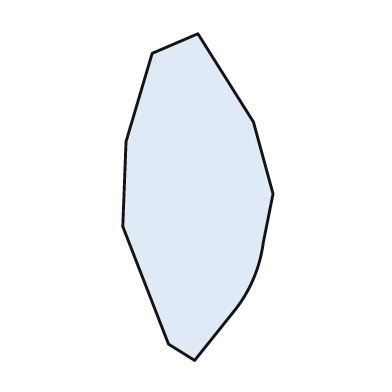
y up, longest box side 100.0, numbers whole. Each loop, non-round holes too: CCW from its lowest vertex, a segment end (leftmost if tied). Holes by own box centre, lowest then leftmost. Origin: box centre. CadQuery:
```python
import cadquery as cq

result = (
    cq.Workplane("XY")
    .moveTo(-1.0, -50.0)
    .lineTo(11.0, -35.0)
    .threePointArc((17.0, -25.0), (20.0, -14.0))
    .lineTo(23.0, 1.0)
    .lineTo(17.0, 23.0)
    .lineTo(0.0, 50.0)
    .lineTo(-14.0, 44.0)
    .lineTo(-22.0, 17.0)
    .lineTo(-23.0, -9.0)
    .lineTo(-9.0, -45.0)
    .close()
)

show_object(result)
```